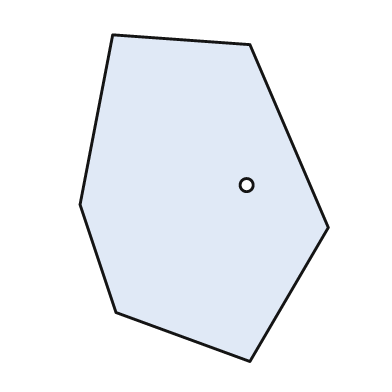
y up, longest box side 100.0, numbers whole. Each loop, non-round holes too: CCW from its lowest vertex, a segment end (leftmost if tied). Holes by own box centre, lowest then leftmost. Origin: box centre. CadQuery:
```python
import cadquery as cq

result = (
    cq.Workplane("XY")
    .moveTo(14.0, -50.0)
    .lineTo(38.0, -9.0)
    .lineTo(14.0, 47.0)
    .lineTo(-28.0, 50.0)
    .lineTo(-38.0, -2.0)
    .lineTo(-27.0, -35.0)
    .close()
    .moveTo(13.0, 4.0)
    .circle(2.0)
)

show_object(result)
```